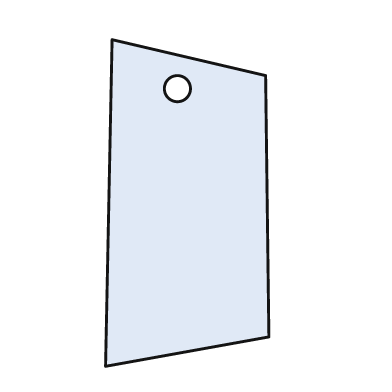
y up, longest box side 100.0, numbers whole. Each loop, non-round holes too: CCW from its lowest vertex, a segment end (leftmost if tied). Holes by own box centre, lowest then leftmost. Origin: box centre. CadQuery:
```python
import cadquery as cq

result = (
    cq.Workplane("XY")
    .moveTo(-25.0, -50.0)
    .lineTo(25.0, -41.0)
    .lineTo(24.0, 39.0)
    .lineTo(-23.0, 50.0)
    .close()
    .moveTo(-3.0, 35.0)
    .circle(4.0)
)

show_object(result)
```